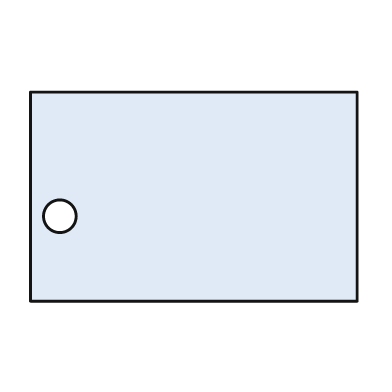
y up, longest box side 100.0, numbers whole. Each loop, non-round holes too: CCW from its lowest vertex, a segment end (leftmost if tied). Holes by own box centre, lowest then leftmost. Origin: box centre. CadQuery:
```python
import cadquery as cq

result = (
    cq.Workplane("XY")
    .moveTo(-50.0, -32.0)
    .lineTo(50.0, -32.0)
    .lineTo(50.0, 32.0)
    .lineTo(-50.0, 32.0)
    .close()
    .moveTo(-41.0, -6.0)
    .circle(5.0)
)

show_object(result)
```